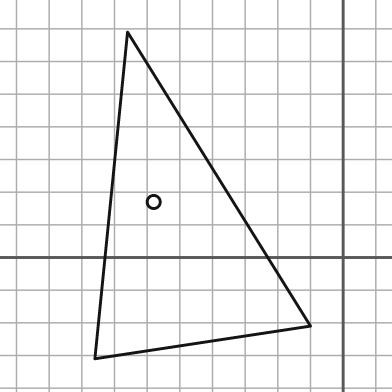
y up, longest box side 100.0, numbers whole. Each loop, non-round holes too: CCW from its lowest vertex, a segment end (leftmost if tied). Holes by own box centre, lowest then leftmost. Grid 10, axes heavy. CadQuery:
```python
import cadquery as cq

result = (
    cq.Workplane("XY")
    .moveTo(-76.0, -31.0)
    .lineTo(-10.0, -21.0)
    .lineTo(-66.0, 69.0)
    .close()
    .moveTo(-58.0, 17.0)
    .circle(2.0)
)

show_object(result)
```